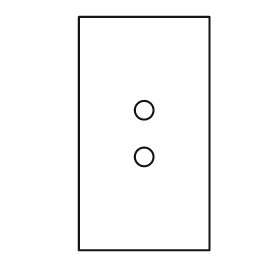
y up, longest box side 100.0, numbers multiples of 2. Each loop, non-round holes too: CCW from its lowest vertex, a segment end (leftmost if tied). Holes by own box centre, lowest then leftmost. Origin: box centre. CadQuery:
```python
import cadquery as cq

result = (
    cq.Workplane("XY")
    .moveTo(-28.0, -50.0)
    .lineTo(28.0, -50.0)
    .lineTo(28.0, 50.0)
    .lineTo(-28.0, 50.0)
    .close()
    .moveTo(0.0, -10.0)
    .circle(4.0)
    .moveTo(0.0, 10.0)
    .circle(4.0)
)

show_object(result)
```